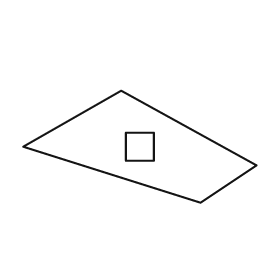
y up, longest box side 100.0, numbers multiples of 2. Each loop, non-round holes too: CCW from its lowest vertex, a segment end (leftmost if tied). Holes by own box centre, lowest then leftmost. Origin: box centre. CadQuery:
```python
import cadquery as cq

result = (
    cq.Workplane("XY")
    .moveTo(26.0, -24.0)
    .lineTo(50.0, -8.0)
    .lineTo(-8.0, 24.0)
    .lineTo(-50.0, 0.0)
    .close()
    .moveTo(-6.0, -6.0)
    .lineTo(6.0, -6.0)
    .lineTo(6.0, 6.0)
    .lineTo(-6.0, 6.0)
    .close()
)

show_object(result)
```